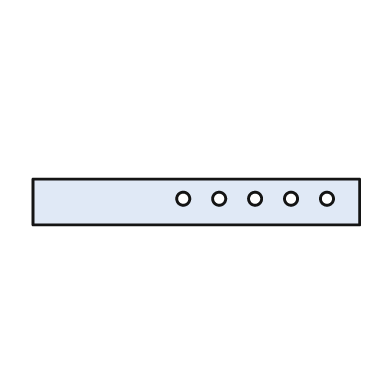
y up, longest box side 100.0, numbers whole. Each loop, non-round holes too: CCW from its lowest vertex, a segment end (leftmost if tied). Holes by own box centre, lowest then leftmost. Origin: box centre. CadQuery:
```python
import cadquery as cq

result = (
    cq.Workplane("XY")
    .moveTo(-50.0, -7.0)
    .lineTo(50.0, -7.0)
    .lineTo(50.0, 7.0)
    .lineTo(-50.0, 7.0)
    .close()
    .moveTo(-4.0, 1.0)
    .circle(2.0)
    .moveTo(7.0, 1.0)
    .circle(2.0)
    .moveTo(18.0, 1.0)
    .circle(2.0)
    .moveTo(29.0, 1.0)
    .circle(2.0)
    .moveTo(40.0, 1.0)
    .circle(2.0)
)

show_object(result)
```